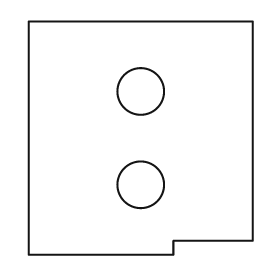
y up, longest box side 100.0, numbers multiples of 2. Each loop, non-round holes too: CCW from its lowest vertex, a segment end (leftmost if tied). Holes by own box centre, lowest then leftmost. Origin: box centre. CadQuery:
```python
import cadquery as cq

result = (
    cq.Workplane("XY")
    .moveTo(-48.0, -50.0)
    .lineTo(14.0, -50.0)
    .lineTo(14.0, -44.0)
    .lineTo(48.0, -44.0)
    .lineTo(48.0, 50.0)
    .lineTo(-48.0, 50.0)
    .close()
    .moveTo(0.0, -20.0)
    .circle(10.0)
    .moveTo(0.0, 20.0)
    .circle(10.0)
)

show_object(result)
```